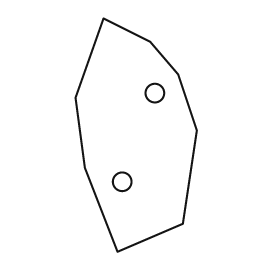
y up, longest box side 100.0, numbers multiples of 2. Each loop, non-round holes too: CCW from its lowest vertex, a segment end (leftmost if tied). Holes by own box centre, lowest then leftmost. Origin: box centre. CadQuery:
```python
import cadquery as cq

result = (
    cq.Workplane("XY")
    .moveTo(-8.0, -50.0)
    .lineTo(20.0, -38.0)
    .lineTo(26.0, 2.0)
    .lineTo(18.0, 26.0)
    .lineTo(6.0, 40.0)
    .lineTo(-14.0, 50.0)
    .lineTo(-26.0, 16.0)
    .lineTo(-22.0, -14.0)
    .close()
    .moveTo(-6.0, -20.0)
    .circle(4.0)
    .moveTo(8.0, 18.0)
    .circle(4.0)
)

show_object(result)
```